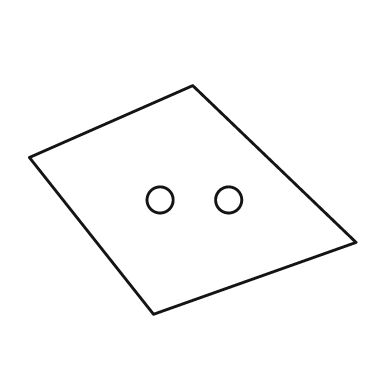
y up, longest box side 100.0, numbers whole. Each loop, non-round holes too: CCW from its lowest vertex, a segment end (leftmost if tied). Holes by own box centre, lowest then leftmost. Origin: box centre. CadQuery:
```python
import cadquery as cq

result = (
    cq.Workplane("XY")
    .moveTo(-12.0, -35.0)
    .lineTo(50.0, -13.0)
    .lineTo(0.0, 35.0)
    .lineTo(-50.0, 13.0)
    .close()
    .moveTo(-10.0, 0.0)
    .circle(4.0)
    .moveTo(11.0, 0.0)
    .circle(4.0)
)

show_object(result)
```